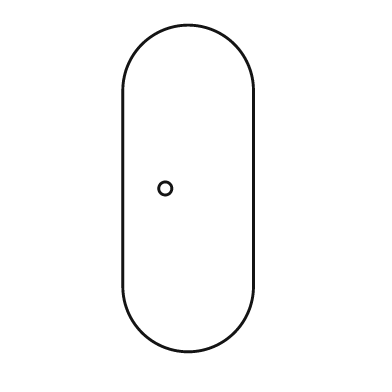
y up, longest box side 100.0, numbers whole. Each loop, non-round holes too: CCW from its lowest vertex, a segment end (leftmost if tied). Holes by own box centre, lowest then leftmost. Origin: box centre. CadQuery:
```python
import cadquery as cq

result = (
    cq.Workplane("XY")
    .moveTo(-20.0, -30.0)
    .threePointArc((0.0, -50.0), (20.0, -30.0))
    .lineTo(20.0, 30.0)
    .threePointArc((0.0, 50.0), (-20.0, 30.0))
    .close()
    .moveTo(-7.0, 0.0)
    .circle(2.0)
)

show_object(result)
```